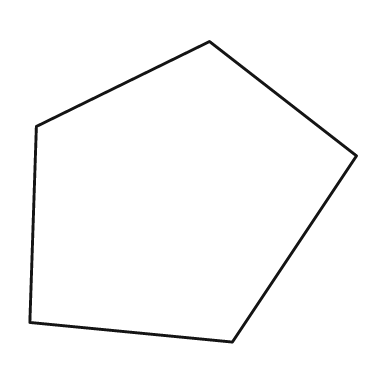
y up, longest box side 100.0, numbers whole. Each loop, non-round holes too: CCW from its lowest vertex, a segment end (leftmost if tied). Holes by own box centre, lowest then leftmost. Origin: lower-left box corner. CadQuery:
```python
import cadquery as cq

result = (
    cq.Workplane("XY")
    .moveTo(62.0, 0.0)
    .lineTo(100.0, 57.0)
    .lineTo(55.0, 92.0)
    .lineTo(2.0, 66.0)
    .lineTo(0.0, 6.0)
    .close()
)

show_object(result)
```